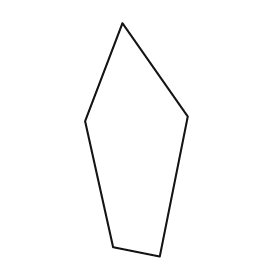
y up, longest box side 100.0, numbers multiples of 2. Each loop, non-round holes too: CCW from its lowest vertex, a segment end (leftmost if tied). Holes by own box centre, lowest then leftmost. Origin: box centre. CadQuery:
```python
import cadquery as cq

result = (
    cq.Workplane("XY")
    .moveTo(10.0, -50.0)
    .lineTo(22.0, 10.0)
    .lineTo(-6.0, 50.0)
    .lineTo(-22.0, 8.0)
    .lineTo(-10.0, -46.0)
    .close()
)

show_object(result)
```